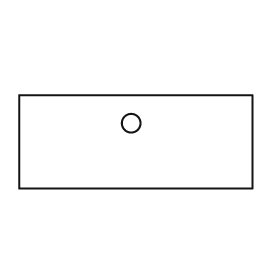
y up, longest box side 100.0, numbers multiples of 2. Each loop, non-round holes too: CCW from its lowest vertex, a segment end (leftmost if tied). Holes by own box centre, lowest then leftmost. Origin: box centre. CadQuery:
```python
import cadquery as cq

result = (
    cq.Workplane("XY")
    .moveTo(-50.0, -20.0)
    .lineTo(50.0, -20.0)
    .lineTo(50.0, 20.0)
    .lineTo(-50.0, 20.0)
    .close()
    .moveTo(-2.0, 8.0)
    .circle(4.0)
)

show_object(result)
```